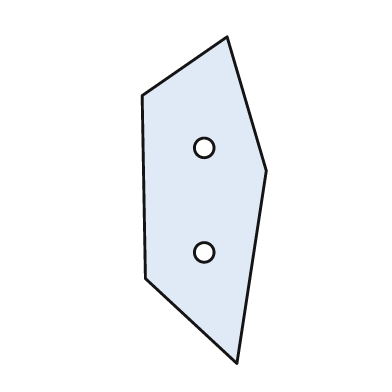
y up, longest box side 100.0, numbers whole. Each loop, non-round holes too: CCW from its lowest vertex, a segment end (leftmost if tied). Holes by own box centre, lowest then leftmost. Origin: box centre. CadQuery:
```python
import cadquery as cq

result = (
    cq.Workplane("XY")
    .moveTo(10.0, -50.0)
    .lineTo(19.0, 9.0)
    .lineTo(7.0, 50.0)
    .lineTo(-19.0, 32.0)
    .lineTo(-18.0, -24.0)
    .close()
    .moveTo(0.0, -16.0)
    .circle(3.0)
    .moveTo(0.0, 16.0)
    .circle(3.0)
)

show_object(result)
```